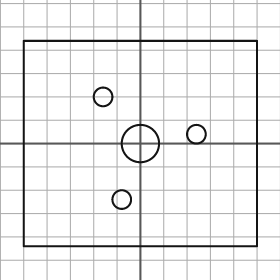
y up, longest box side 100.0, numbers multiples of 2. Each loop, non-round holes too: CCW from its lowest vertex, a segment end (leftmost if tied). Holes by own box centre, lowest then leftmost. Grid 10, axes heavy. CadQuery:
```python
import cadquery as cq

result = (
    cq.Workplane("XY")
    .moveTo(-50.0, -44.0)
    .lineTo(50.0, -44.0)
    .lineTo(50.0, 44.0)
    .lineTo(-50.0, 44.0)
    .close()
    .moveTo(-8.0, -24.0)
    .circle(4.0)
    .moveTo(0.0, 0.0)
    .circle(8.0)
    .moveTo(24.0, 4.0)
    .circle(4.0)
    .moveTo(-16.0, 20.0)
    .circle(4.0)
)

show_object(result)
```